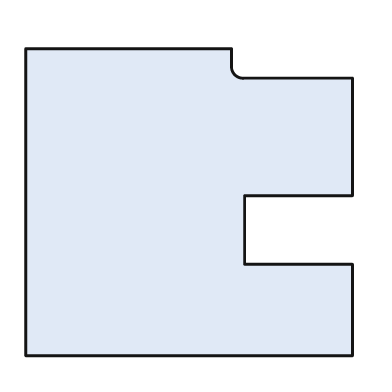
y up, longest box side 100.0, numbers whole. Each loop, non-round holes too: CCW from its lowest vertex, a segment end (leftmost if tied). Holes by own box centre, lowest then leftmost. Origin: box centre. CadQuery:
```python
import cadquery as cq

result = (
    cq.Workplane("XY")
    .moveTo(-50.0, -47.0)
    .lineTo(50.0, -47.0)
    .lineTo(50.0, -19.0)
    .lineTo(17.0, -19.0)
    .lineTo(17.0, 2.0)
    .lineTo(50.0, 2.0)
    .lineTo(50.0, 38.0)
    .lineTo(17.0, 38.0)
    .threePointArc((14.0, 39.0), (13.0, 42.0))
    .lineTo(13.0, 47.0)
    .lineTo(-50.0, 47.0)
    .close()
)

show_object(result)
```